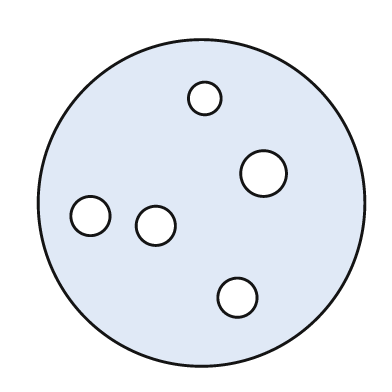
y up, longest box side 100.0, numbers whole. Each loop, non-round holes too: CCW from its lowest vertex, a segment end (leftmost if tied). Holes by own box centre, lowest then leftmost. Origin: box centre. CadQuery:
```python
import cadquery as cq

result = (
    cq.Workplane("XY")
    .moveTo(0.0, 0.0)
    .circle(50.0)
    .moveTo(11.0, -29.0)
    .circle(6.0)
    .moveTo(-14.0, -7.0)
    .circle(6.0)
    .moveTo(-34.0, -4.0)
    .circle(6.0)
    .moveTo(19.0, 9.0)
    .circle(7.0)
    .moveTo(1.0, 32.0)
    .circle(5.0)
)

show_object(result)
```